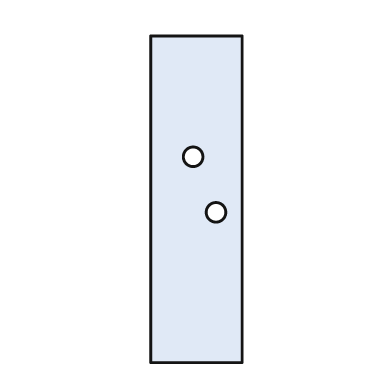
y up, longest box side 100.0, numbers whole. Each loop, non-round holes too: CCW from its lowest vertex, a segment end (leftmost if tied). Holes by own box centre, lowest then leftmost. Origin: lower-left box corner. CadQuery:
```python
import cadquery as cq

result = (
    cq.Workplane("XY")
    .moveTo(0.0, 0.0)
    .lineTo(28.0, 0.0)
    .lineTo(28.0, 100.0)
    .lineTo(0.0, 100.0)
    .close()
    .moveTo(20.0, 46.0)
    .circle(3.0)
    .moveTo(13.0, 63.0)
    .circle(3.0)
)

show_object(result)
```